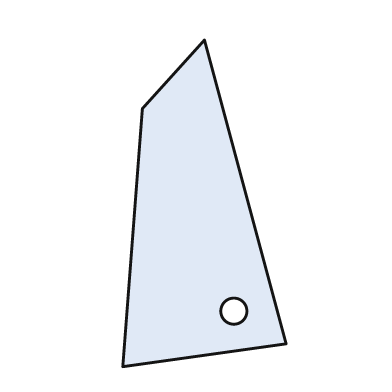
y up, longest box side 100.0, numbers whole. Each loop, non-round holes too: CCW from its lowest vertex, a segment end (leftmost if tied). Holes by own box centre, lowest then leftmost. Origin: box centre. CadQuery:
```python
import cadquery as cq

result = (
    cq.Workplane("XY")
    .moveTo(-25.0, -50.0)
    .lineTo(25.0, -43.0)
    .lineTo(0.0, 50.0)
    .lineTo(-19.0, 29.0)
    .close()
    .moveTo(9.0, -33.0)
    .circle(4.0)
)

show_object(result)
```